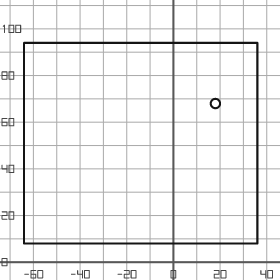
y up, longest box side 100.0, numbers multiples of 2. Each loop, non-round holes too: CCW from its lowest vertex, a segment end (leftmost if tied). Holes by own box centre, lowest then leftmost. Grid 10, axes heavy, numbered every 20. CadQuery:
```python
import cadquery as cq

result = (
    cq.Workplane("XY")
    .moveTo(-64.0, 8.0)
    .lineTo(36.0, 8.0)
    .lineTo(36.0, 94.0)
    .lineTo(-64.0, 94.0)
    .close()
    .moveTo(18.0, 68.0)
    .circle(2.0)
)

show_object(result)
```